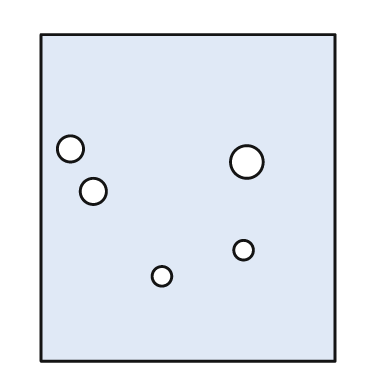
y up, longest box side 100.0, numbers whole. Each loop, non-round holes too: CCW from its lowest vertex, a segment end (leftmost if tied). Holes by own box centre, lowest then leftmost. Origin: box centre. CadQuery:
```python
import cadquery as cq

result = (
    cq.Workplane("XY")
    .moveTo(-45.0, -50.0)
    .lineTo(45.0, -50.0)
    .lineTo(45.0, 50.0)
    .lineTo(-45.0, 50.0)
    .close()
    .moveTo(-8.0, -24.0)
    .circle(3.0)
    .moveTo(17.0, -16.0)
    .circle(3.0)
    .moveTo(-29.0, 2.0)
    .circle(4.0)
    .moveTo(18.0, 11.0)
    .circle(5.0)
    .moveTo(-36.0, 15.0)
    .circle(4.0)
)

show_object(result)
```